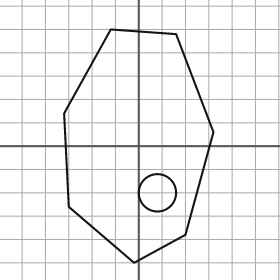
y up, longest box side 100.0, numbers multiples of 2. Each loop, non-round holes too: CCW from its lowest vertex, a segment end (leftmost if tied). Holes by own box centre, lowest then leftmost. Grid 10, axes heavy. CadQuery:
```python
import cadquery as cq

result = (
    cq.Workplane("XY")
    .moveTo(-2.0, -50.0)
    .lineTo(20.0, -38.0)
    .lineTo(32.0, 6.0)
    .lineTo(16.0, 48.0)
    .lineTo(-12.0, 50.0)
    .lineTo(-32.0, 14.0)
    .lineTo(-30.0, -26.0)
    .close()
    .moveTo(8.0, -20.0)
    .circle(8.0)
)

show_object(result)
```